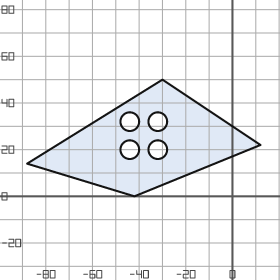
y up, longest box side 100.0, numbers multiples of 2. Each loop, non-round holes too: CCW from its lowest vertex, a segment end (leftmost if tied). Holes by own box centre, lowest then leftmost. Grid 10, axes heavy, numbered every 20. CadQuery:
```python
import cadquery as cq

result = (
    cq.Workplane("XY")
    .moveTo(-42.0, 0.0)
    .lineTo(12.0, 22.0)
    .lineTo(-30.0, 50.0)
    .lineTo(-88.0, 14.0)
    .close()
    .moveTo(-44.0, 20.0)
    .circle(4.0)
    .moveTo(-32.0, 20.0)
    .circle(4.0)
    .moveTo(-44.0, 32.0)
    .circle(4.0)
    .moveTo(-32.0, 32.0)
    .circle(4.0)
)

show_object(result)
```